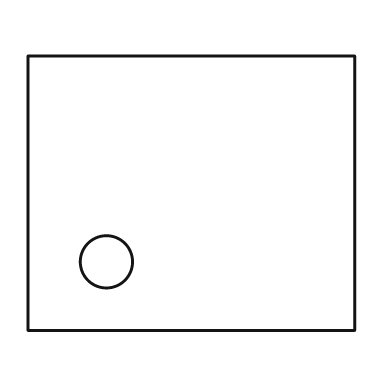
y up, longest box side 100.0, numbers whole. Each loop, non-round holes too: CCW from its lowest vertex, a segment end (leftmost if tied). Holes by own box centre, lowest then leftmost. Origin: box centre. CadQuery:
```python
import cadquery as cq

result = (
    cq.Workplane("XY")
    .moveTo(-50.0, -42.0)
    .lineTo(50.0, -42.0)
    .lineTo(50.0, 42.0)
    .lineTo(-50.0, 42.0)
    .close()
    .moveTo(-26.0, -21.0)
    .circle(8.0)
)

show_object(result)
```